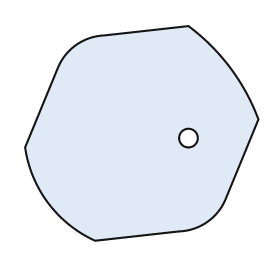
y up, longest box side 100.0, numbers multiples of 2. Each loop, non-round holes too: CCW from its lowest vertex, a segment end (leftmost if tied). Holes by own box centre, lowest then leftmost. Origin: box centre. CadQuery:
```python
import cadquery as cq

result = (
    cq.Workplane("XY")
    .moveTo(-20.0, -46.0)
    .lineTo(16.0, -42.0)
    .threePointArc((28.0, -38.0), (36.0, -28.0))
    .lineTo(50.0, 6.0)
    .threePointArc((38.0, 28.0), (20.0, 46.0))
    .lineTo(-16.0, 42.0)
    .threePointArc((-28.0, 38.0), (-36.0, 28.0))
    .lineTo(-50.0, -6.0)
    .threePointArc((-40.0, -30.0), (-20.0, -46.0))
    .close()
    .moveTo(20.0, -2.0)
    .circle(4.0)
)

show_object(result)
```